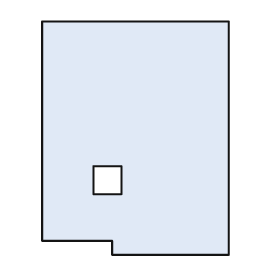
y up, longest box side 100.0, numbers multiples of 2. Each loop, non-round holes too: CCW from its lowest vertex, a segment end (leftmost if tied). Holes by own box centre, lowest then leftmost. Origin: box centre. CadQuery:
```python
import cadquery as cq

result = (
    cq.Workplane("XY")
    .moveTo(-10.0, -50.0)
    .lineTo(40.0, -50.0)
    .lineTo(40.0, 50.0)
    .lineTo(-40.0, 50.0)
    .lineTo(-40.0, -44.0)
    .lineTo(-10.0, -44.0)
    .close()
    .moveTo(-18.0, -24.0)
    .lineTo(-6.0, -24.0)
    .lineTo(-6.0, -12.0)
    .lineTo(-18.0, -12.0)
    .close()
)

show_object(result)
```